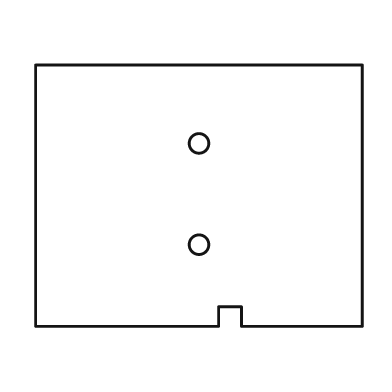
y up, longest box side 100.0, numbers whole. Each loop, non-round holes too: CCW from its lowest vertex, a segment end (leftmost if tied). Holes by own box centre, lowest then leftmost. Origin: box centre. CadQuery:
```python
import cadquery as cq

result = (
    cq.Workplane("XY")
    .moveTo(-50.0, -40.0)
    .lineTo(6.0, -40.0)
    .lineTo(6.0, -34.0)
    .lineTo(13.0, -34.0)
    .lineTo(13.0, -40.0)
    .lineTo(50.0, -40.0)
    .lineTo(50.0, 40.0)
    .lineTo(-50.0, 40.0)
    .close()
    .moveTo(0.0, -15.0)
    .circle(3.0)
    .moveTo(0.0, 16.0)
    .circle(3.0)
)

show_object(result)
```